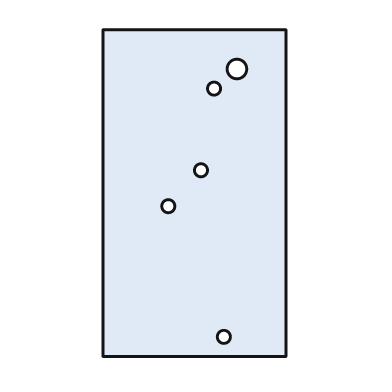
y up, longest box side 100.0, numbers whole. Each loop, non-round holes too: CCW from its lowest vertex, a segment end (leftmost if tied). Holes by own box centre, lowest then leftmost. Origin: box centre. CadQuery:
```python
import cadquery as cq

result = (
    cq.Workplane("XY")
    .moveTo(-28.0, -50.0)
    .lineTo(28.0, -50.0)
    .lineTo(28.0, 50.0)
    .lineTo(-28.0, 50.0)
    .close()
    .moveTo(9.0, -44.0)
    .circle(2.0)
    .moveTo(-8.0, -4.0)
    .circle(2.0)
    .moveTo(2.0, 7.0)
    .circle(2.0)
    .moveTo(6.0, 32.0)
    .circle(2.0)
    .moveTo(13.0, 38.0)
    .circle(3.0)
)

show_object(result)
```